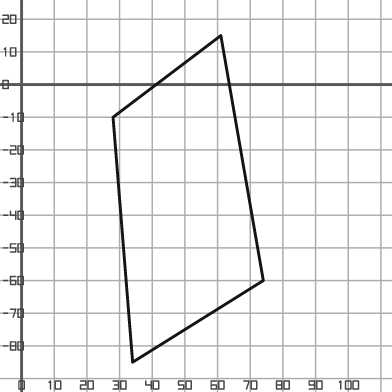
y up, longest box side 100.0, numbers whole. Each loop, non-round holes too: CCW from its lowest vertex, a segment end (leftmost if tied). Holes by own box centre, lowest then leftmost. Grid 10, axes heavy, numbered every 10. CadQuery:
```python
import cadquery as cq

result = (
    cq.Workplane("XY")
    .moveTo(34.0, -85.0)
    .lineTo(74.0, -60.0)
    .lineTo(61.0, 15.0)
    .lineTo(28.0, -10.0)
    .close()
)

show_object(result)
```